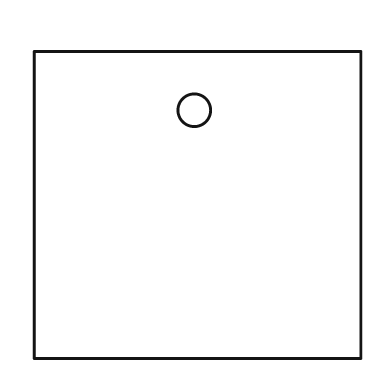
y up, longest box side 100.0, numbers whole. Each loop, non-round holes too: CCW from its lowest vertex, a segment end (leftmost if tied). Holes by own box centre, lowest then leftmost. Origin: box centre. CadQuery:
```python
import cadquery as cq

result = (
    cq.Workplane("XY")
    .moveTo(-50.0, -47.0)
    .lineTo(50.0, -47.0)
    .lineTo(50.0, 47.0)
    .lineTo(-50.0, 47.0)
    .close()
    .moveTo(-1.0, 29.0)
    .circle(5.0)
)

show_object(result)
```